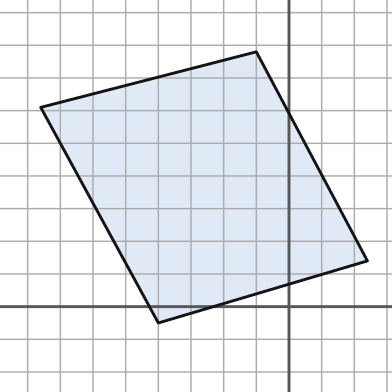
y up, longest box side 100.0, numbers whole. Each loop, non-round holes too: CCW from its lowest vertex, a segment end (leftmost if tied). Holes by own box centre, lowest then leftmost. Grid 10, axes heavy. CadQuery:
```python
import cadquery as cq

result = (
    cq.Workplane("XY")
    .moveTo(-40.0, -5.0)
    .lineTo(24.0, 14.0)
    .lineTo(-10.0, 78.0)
    .lineTo(-76.0, 61.0)
    .close()
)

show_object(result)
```